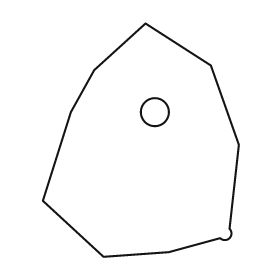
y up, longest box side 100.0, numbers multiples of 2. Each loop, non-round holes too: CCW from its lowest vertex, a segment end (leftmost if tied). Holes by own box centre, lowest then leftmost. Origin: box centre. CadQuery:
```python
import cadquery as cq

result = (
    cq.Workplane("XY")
    .moveTo(-16.0, -50.0)
    .lineTo(12.0, -48.0)
    .lineTo(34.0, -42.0)
    .threePointArc((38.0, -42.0), (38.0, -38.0))
    .lineTo(42.0, -2.0)
    .lineTo(30.0, 32.0)
    .lineTo(2.0, 50.0)
    .lineTo(-20.0, 30.0)
    .lineTo(-30.0, 12.0)
    .lineTo(-42.0, -26.0)
    .close()
    .moveTo(6.0, 12.0)
    .circle(6.0)
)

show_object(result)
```